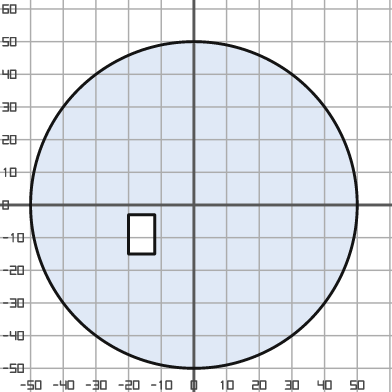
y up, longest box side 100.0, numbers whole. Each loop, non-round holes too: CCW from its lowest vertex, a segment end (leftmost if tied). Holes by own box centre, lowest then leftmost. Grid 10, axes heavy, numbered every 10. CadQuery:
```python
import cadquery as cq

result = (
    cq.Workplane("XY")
    .moveTo(0.0, 0.0)
    .circle(50.0)
    .moveTo(-20.0, -15.0)
    .lineTo(-12.0, -15.0)
    .lineTo(-12.0, -3.0)
    .lineTo(-20.0, -3.0)
    .close()
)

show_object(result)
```